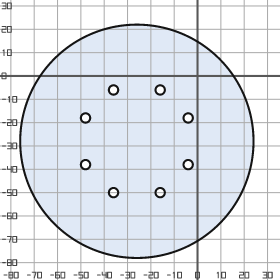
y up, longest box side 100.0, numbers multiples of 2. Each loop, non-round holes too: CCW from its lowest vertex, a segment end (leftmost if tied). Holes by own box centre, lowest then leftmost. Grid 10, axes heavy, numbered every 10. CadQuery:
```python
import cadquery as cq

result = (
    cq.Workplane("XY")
    .moveTo(-26.0, -28.0)
    .circle(50.0)
    .moveTo(-36.0, -50.0)
    .circle(2.0)
    .moveTo(-16.0, -50.0)
    .circle(2.0)
    .moveTo(-48.0, -38.0)
    .circle(2.0)
    .moveTo(-4.0, -38.0)
    .circle(2.0)
    .moveTo(-48.0, -18.0)
    .circle(2.0)
    .moveTo(-4.0, -18.0)
    .circle(2.0)
    .moveTo(-36.0, -6.0)
    .circle(2.0)
    .moveTo(-16.0, -6.0)
    .circle(2.0)
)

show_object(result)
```